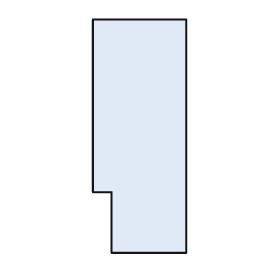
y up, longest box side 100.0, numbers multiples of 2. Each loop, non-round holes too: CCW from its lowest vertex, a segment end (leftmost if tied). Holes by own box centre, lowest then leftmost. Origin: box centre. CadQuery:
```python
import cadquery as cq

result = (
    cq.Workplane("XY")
    .moveTo(-12.0, -50.0)
    .lineTo(20.0, -50.0)
    .lineTo(20.0, 50.0)
    .lineTo(-20.0, 50.0)
    .lineTo(-20.0, -24.0)
    .lineTo(-12.0, -24.0)
    .close()
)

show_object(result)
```